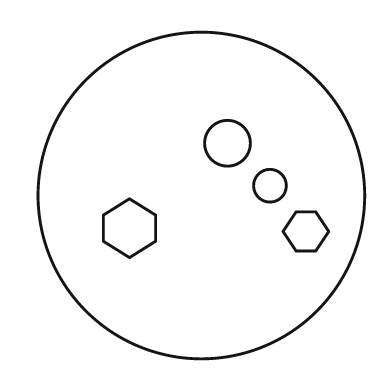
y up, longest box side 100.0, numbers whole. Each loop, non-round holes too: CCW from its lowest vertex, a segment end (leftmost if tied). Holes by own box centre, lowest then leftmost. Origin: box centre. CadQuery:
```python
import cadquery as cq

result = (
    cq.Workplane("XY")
    .moveTo(0.0, 0.0)
    .circle(50.0)
    .moveTo(29.0, -17.0)
    .lineTo(35.0, -17.0)
    .lineTo(39.0, -11.0)
    .lineTo(35.0, -5.0)
    .lineTo(29.0, -5.0)
    .lineTo(25.0, -11.0)
    .close()
    .moveTo(-22.0, -19.0)
    .lineTo(-14.0, -14.0)
    .lineTo(-14.0, -6.0)
    .lineTo(-22.0, -1.0)
    .lineTo(-30.0, -6.0)
    .lineTo(-30.0, -14.0)
    .close()
    .moveTo(21.0, 3.0)
    .circle(5.0)
    .moveTo(8.0, 16.0)
    .circle(7.0)
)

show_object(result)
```